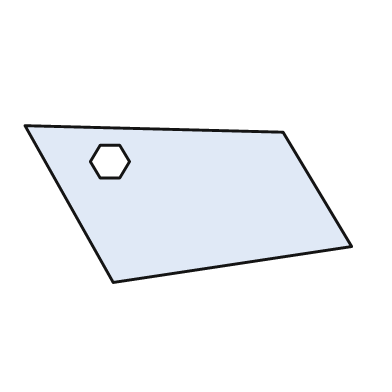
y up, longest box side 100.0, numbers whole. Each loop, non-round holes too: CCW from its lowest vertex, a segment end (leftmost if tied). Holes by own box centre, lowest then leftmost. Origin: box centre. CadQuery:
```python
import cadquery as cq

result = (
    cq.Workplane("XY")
    .moveTo(-23.0, -24.0)
    .lineTo(50.0, -13.0)
    .lineTo(29.0, 22.0)
    .lineTo(-50.0, 24.0)
    .close()
    .moveTo(-27.0, 8.0)
    .lineTo(-21.0, 8.0)
    .lineTo(-18.0, 13.0)
    .lineTo(-21.0, 18.0)
    .lineTo(-27.0, 18.0)
    .lineTo(-30.0, 13.0)
    .close()
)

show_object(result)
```